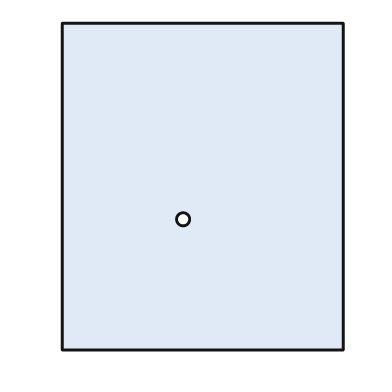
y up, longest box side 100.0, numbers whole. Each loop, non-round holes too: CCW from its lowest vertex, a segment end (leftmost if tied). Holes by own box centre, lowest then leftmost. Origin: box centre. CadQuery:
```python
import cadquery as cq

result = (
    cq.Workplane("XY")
    .moveTo(-43.0, -50.0)
    .lineTo(43.0, -50.0)
    .lineTo(43.0, 50.0)
    .lineTo(-43.0, 50.0)
    .close()
    .moveTo(-6.0, -10.0)
    .circle(2.0)
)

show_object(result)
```